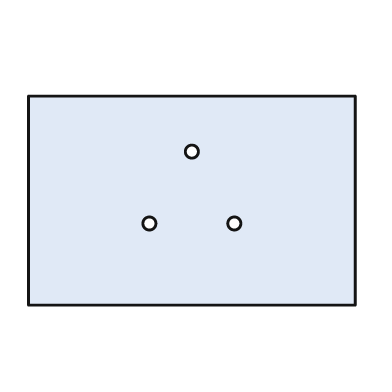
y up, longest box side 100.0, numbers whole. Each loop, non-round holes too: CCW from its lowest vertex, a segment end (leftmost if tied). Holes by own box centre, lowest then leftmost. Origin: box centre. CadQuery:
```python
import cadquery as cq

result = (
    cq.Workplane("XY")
    .moveTo(-50.0, -32.0)
    .lineTo(50.0, -32.0)
    .lineTo(50.0, 32.0)
    .lineTo(-50.0, 32.0)
    .close()
    .moveTo(-13.0, -7.0)
    .circle(2.0)
    .moveTo(13.0, -7.0)
    .circle(2.0)
    .moveTo(0.0, 15.0)
    .circle(2.0)
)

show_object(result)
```